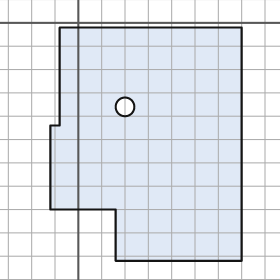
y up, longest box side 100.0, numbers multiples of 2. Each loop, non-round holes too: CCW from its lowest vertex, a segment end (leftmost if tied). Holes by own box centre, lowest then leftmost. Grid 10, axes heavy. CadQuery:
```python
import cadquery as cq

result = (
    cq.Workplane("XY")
    .moveTo(16.0, -102.0)
    .lineTo(70.0, -102.0)
    .lineTo(70.0, -2.0)
    .lineTo(-8.0, -2.0)
    .lineTo(-8.0, -44.0)
    .lineTo(-12.0, -44.0)
    .lineTo(-12.0, -80.0)
    .lineTo(16.0, -80.0)
    .close()
    .moveTo(20.0, -36.0)
    .circle(4.0)
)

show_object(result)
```